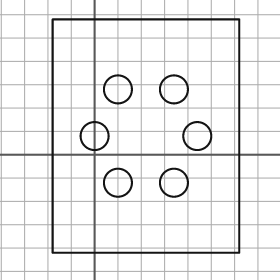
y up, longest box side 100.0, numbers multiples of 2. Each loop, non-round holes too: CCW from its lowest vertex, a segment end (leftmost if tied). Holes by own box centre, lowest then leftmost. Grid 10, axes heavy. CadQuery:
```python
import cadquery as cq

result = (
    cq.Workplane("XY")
    .moveTo(-18.0, -42.0)
    .lineTo(62.0, -42.0)
    .lineTo(62.0, 58.0)
    .lineTo(-18.0, 58.0)
    .close()
    .moveTo(10.0, -12.0)
    .circle(6.0)
    .moveTo(34.0, -12.0)
    .circle(6.0)
    .moveTo(0.0, 8.0)
    .circle(6.0)
    .moveTo(44.0, 8.0)
    .circle(6.0)
    .moveTo(10.0, 28.0)
    .circle(6.0)
    .moveTo(34.0, 28.0)
    .circle(6.0)
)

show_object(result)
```